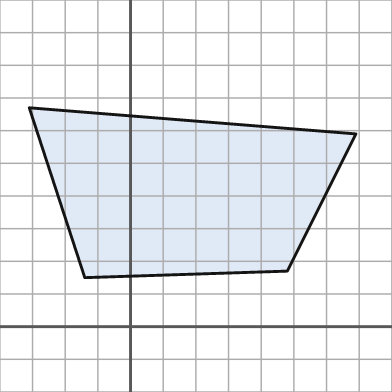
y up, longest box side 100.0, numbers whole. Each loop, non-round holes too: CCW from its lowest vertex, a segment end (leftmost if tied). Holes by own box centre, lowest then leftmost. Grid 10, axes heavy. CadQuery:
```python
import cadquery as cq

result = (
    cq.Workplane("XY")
    .moveTo(-14.0, 15.0)
    .lineTo(48.0, 17.0)
    .lineTo(69.0, 59.0)
    .lineTo(-31.0, 67.0)
    .close()
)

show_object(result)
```